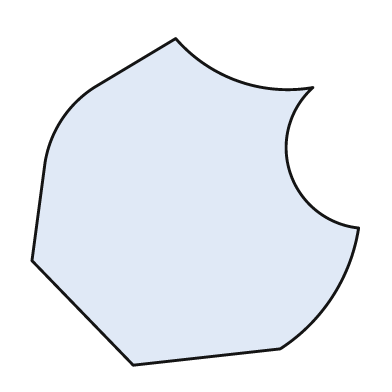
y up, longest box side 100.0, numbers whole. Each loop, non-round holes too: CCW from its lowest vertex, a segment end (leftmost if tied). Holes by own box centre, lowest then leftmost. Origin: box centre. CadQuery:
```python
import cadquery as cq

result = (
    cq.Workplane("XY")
    .moveTo(-19.0, -50.0)
    .lineTo(26.0, -45.0)
    .threePointArc((42.0, -29.0), (50.0, -8.0))
    .threePointArc((29.0, 9.0), (36.0, 35.0))
    .threePointArc((13.0, 37.0), (-6.0, 50.0))
    .lineTo(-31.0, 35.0)
    .threePointArc((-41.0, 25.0), (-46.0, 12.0))
    .lineTo(-50.0, -18.0)
    .close()
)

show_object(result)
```